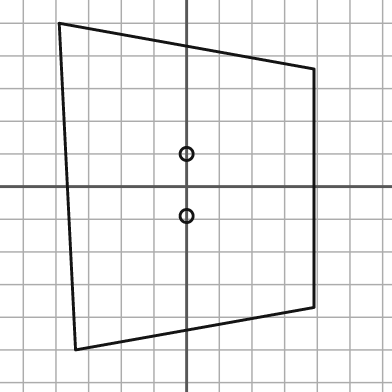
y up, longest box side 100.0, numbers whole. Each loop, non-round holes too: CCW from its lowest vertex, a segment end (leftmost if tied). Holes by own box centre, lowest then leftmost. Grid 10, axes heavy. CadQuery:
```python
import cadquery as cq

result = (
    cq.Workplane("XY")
    .moveTo(-34.0, -50.0)
    .lineTo(39.0, -37.0)
    .lineTo(39.0, 36.0)
    .lineTo(-39.0, 50.0)
    .close()
    .moveTo(0.0, -9.0)
    .circle(2.0)
    .moveTo(0.0, 10.0)
    .circle(2.0)
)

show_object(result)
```